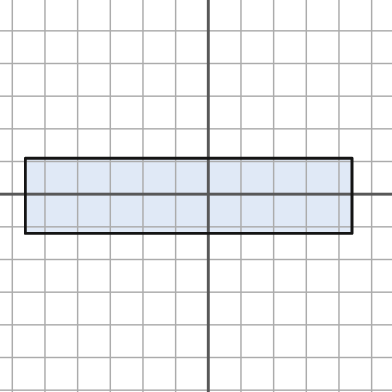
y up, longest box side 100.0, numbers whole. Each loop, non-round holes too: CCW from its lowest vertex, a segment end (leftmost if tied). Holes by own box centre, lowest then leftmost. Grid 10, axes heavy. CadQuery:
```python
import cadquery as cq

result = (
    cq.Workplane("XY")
    .moveTo(-56.0, -12.0)
    .lineTo(44.0, -12.0)
    .lineTo(44.0, 11.0)
    .lineTo(-56.0, 11.0)
    .close()
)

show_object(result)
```